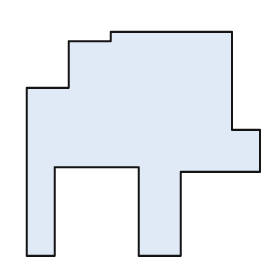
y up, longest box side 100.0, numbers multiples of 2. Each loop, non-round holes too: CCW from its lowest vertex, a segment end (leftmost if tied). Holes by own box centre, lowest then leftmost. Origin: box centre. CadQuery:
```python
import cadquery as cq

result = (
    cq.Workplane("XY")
    .moveTo(-50.0, -48.0)
    .lineTo(-38.0, -48.0)
    .lineTo(-38.0, -10.0)
    .lineTo(-2.0, -10.0)
    .lineTo(-2.0, -48.0)
    .lineTo(16.0, -48.0)
    .lineTo(16.0, -12.0)
    .lineTo(50.0, -12.0)
    .lineTo(50.0, 6.0)
    .lineTo(38.0, 6.0)
    .lineTo(38.0, 48.0)
    .lineTo(-14.0, 48.0)
    .lineTo(-14.0, 44.0)
    .lineTo(-32.0, 44.0)
    .lineTo(-32.0, 24.0)
    .lineTo(-50.0, 24.0)
    .close()
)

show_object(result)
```